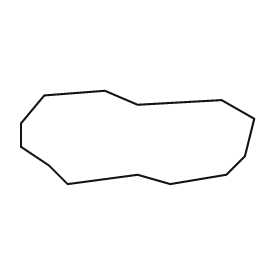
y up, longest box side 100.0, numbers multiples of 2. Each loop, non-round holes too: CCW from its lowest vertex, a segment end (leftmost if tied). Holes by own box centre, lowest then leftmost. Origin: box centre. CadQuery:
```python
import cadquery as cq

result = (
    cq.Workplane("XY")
    .moveTo(-30.0, -20.0)
    .lineTo(0.0, -16.0)
    .lineTo(14.0, -20.0)
    .lineTo(38.0, -16.0)
    .lineTo(46.0, -8.0)
    .lineTo(50.0, 8.0)
    .lineTo(36.0, 16.0)
    .lineTo(0.0, 14.0)
    .lineTo(-14.0, 20.0)
    .lineTo(-40.0, 18.0)
    .lineTo(-50.0, 6.0)
    .lineTo(-50.0, -4.0)
    .lineTo(-38.0, -12.0)
    .close()
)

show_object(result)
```